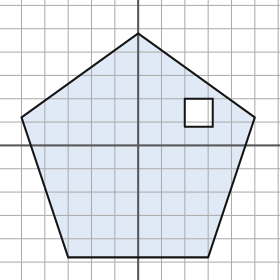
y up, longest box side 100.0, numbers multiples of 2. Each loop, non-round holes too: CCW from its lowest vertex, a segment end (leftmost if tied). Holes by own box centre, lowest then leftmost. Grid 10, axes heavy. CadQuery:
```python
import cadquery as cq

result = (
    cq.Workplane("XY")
    .moveTo(-30.0, -48.0)
    .lineTo(30.0, -48.0)
    .lineTo(50.0, 12.0)
    .lineTo(0.0, 48.0)
    .lineTo(-50.0, 12.0)
    .close()
    .moveTo(20.0, 8.0)
    .lineTo(32.0, 8.0)
    .lineTo(32.0, 20.0)
    .lineTo(20.0, 20.0)
    .close()
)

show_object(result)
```